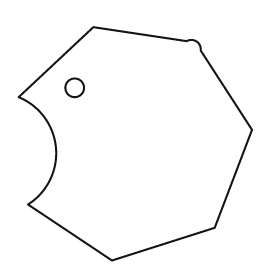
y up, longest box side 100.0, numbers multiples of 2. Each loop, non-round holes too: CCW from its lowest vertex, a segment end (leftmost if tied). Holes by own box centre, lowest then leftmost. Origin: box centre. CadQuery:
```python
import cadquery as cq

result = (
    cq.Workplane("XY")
    .moveTo(-10.0, -50.0)
    .lineTo(34.0, -36.0)
    .lineTo(50.0, 6.0)
    .lineTo(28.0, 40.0)
    .threePointArc((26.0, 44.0), (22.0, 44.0))
    .lineTo(-18.0, 50.0)
    .lineTo(-50.0, 20.0)
    .threePointArc((-34.0, -2.0), (-46.0, -26.0))
    .close()
    .moveTo(-26.0, 24.0)
    .circle(4.0)
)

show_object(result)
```